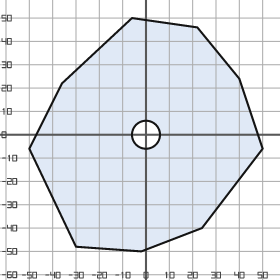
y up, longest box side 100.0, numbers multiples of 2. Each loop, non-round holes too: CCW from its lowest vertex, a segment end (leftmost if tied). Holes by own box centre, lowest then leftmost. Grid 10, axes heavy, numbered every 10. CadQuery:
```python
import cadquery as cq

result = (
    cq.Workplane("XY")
    .moveTo(-2.0, -50.0)
    .lineTo(24.0, -40.0)
    .lineTo(50.0, -6.0)
    .lineTo(40.0, 24.0)
    .lineTo(22.0, 46.0)
    .lineTo(-6.0, 50.0)
    .lineTo(-36.0, 22.0)
    .lineTo(-50.0, -6.0)
    .lineTo(-30.0, -48.0)
    .close()
    .moveTo(0.0, 0.0)
    .circle(6.0)
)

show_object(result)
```